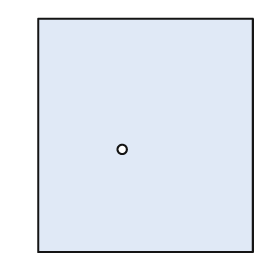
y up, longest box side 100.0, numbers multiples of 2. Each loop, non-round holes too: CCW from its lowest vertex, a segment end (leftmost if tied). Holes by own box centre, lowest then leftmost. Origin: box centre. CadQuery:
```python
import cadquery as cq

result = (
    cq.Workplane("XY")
    .moveTo(-46.0, -50.0)
    .lineTo(46.0, -50.0)
    .lineTo(46.0, 50.0)
    .lineTo(-46.0, 50.0)
    .close()
    .moveTo(-10.0, -6.0)
    .circle(2.0)
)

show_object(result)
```